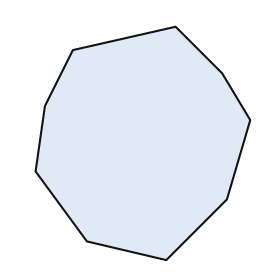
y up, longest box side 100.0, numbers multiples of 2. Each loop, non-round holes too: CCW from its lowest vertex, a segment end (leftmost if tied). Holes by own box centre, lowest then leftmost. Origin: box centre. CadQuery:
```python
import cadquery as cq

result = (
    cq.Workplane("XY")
    .moveTo(10.0, -50.0)
    .lineTo(36.0, -24.0)
    .lineTo(46.0, 10.0)
    .lineTo(34.0, 30.0)
    .lineTo(14.0, 50.0)
    .lineTo(-30.0, 40.0)
    .lineTo(-42.0, 16.0)
    .lineTo(-46.0, -12.0)
    .lineTo(-24.0, -42.0)
    .close()
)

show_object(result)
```